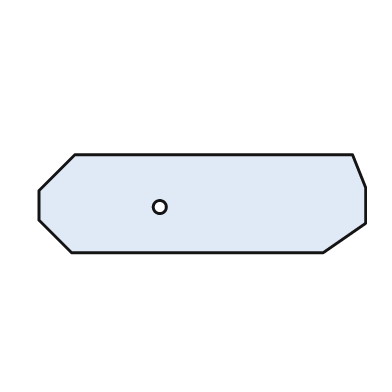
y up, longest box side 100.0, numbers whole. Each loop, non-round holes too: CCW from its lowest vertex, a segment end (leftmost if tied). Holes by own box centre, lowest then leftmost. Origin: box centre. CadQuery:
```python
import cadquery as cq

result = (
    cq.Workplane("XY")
    .moveTo(-40.0, -15.0)
    .lineTo(37.0, -15.0)
    .lineTo(50.0, -6.0)
    .lineTo(50.0, 5.0)
    .lineTo(46.0, 15.0)
    .lineTo(-39.0, 15.0)
    .lineTo(-50.0, 4.0)
    .lineTo(-50.0, -5.0)
    .close()
    .moveTo(-13.0, -1.0)
    .circle(2.0)
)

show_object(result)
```